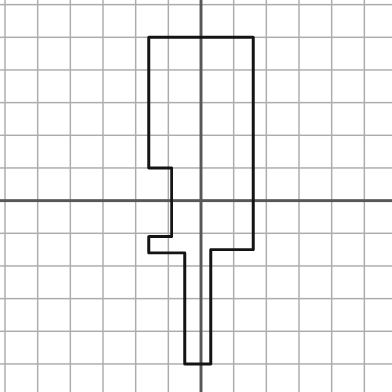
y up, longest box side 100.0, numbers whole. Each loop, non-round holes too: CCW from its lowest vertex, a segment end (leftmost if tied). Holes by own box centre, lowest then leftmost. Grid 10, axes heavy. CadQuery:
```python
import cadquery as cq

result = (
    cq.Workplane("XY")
    .moveTo(-5.0, -50.0)
    .lineTo(3.0, -50.0)
    .lineTo(3.0, -15.0)
    .lineTo(16.0, -15.0)
    .lineTo(16.0, 50.0)
    .lineTo(-16.0, 50.0)
    .lineTo(-16.0, 10.0)
    .lineTo(-9.0, 10.0)
    .lineTo(-9.0, -11.0)
    .lineTo(-16.0, -11.0)
    .lineTo(-16.0, -16.0)
    .lineTo(-5.0, -16.0)
    .close()
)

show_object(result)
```